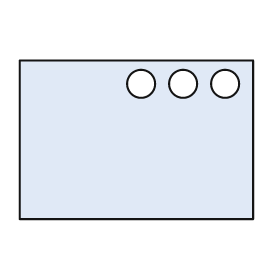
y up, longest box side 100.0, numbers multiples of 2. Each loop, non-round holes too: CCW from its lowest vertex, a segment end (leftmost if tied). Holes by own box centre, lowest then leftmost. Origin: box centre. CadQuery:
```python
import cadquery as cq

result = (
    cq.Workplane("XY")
    .moveTo(-50.0, -34.0)
    .lineTo(50.0, -34.0)
    .lineTo(50.0, 34.0)
    .lineTo(-50.0, 34.0)
    .close()
    .moveTo(2.0, 24.0)
    .circle(6.0)
    .moveTo(20.0, 24.0)
    .circle(6.0)
    .moveTo(38.0, 24.0)
    .circle(6.0)
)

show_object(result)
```